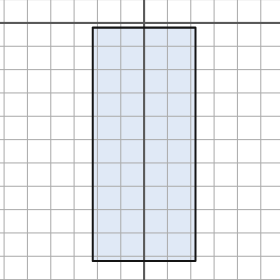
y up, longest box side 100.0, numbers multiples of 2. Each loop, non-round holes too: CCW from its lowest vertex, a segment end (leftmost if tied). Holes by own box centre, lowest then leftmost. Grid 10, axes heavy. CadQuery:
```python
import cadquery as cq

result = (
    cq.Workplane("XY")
    .moveTo(-22.0, -102.0)
    .lineTo(22.0, -102.0)
    .lineTo(22.0, -2.0)
    .lineTo(-22.0, -2.0)
    .close()
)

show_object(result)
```